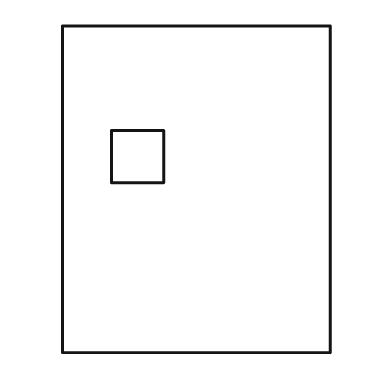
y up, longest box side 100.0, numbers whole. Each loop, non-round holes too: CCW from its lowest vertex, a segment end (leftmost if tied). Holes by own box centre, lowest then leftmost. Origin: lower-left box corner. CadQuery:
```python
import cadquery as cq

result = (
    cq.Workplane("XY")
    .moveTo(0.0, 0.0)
    .lineTo(82.0, 0.0)
    .lineTo(82.0, 100.0)
    .lineTo(0.0, 100.0)
    .close()
    .moveTo(15.0, 52.0)
    .lineTo(31.0, 52.0)
    .lineTo(31.0, 68.0)
    .lineTo(15.0, 68.0)
    .close()
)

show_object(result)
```